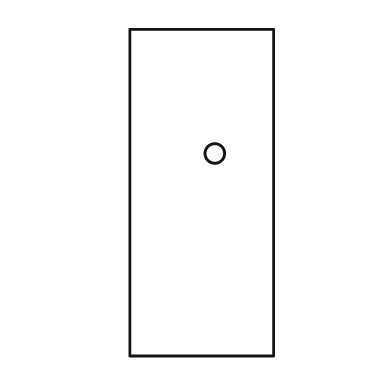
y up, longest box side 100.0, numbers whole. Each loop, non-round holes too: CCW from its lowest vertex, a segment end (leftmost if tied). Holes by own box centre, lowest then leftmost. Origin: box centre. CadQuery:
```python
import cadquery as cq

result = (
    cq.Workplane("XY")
    .moveTo(-22.0, -50.0)
    .lineTo(22.0, -50.0)
    .lineTo(22.0, 50.0)
    .lineTo(-22.0, 50.0)
    .close()
    .moveTo(4.0, 12.0)
    .circle(3.0)
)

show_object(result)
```